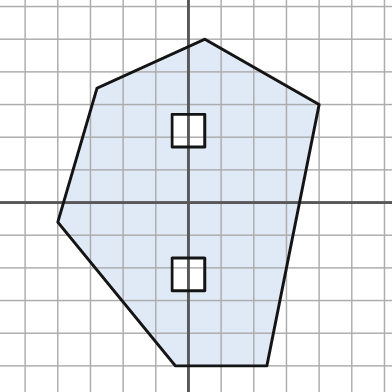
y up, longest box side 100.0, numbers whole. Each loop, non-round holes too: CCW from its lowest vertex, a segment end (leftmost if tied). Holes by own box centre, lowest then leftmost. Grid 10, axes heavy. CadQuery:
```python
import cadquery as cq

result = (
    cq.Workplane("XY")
    .moveTo(-4.0, -50.0)
    .lineTo(24.0, -50.0)
    .lineTo(40.0, 30.0)
    .lineTo(5.0, 50.0)
    .lineTo(-28.0, 35.0)
    .lineTo(-40.0, -6.0)
    .close()
    .moveTo(-5.0, -27.0)
    .lineTo(5.0, -27.0)
    .lineTo(5.0, -17.0)
    .lineTo(-5.0, -17.0)
    .close()
    .moveTo(-5.0, 17.0)
    .lineTo(5.0, 17.0)
    .lineTo(5.0, 27.0)
    .lineTo(-5.0, 27.0)
    .close()
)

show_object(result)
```